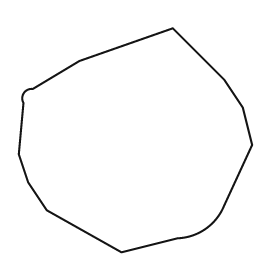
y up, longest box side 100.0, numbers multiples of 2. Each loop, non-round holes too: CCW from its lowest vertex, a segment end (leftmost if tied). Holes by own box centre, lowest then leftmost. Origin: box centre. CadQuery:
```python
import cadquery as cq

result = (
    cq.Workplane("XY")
    .moveTo(-6.0, -48.0)
    .lineTo(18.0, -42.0)
    .threePointArc((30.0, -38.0), (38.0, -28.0))
    .lineTo(50.0, -2.0)
    .lineTo(46.0, 14.0)
    .lineTo(38.0, 26.0)
    .lineTo(16.0, 48.0)
    .lineTo(-24.0, 34.0)
    .lineTo(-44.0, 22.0)
    .threePointArc((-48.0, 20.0), (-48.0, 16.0))
    .lineTo(-50.0, -6.0)
    .lineTo(-46.0, -18.0)
    .lineTo(-38.0, -30.0)
    .close()
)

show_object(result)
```